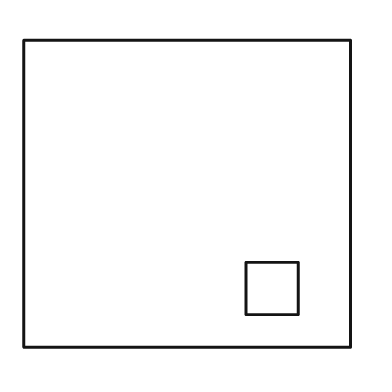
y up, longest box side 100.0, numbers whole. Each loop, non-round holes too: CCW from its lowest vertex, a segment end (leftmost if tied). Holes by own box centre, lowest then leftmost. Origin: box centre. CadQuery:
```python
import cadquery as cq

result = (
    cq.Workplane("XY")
    .moveTo(-50.0, -47.0)
    .lineTo(50.0, -47.0)
    .lineTo(50.0, 47.0)
    .lineTo(-50.0, 47.0)
    .close()
    .moveTo(18.0, -37.0)
    .lineTo(34.0, -37.0)
    .lineTo(34.0, -21.0)
    .lineTo(18.0, -21.0)
    .close()
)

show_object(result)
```